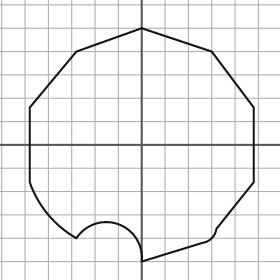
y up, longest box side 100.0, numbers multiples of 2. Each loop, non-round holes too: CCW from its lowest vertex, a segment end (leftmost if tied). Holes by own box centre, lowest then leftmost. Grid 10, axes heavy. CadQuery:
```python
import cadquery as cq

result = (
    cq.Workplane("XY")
    .moveTo(0.0, -50.0)
    .lineTo(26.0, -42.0)
    .threePointArc((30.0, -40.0), (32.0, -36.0))
    .lineTo(48.0, -16.0)
    .lineTo(48.0, 16.0)
    .lineTo(30.0, 40.0)
    .lineTo(0.0, 50.0)
    .lineTo(-28.0, 40.0)
    .lineTo(-48.0, 16.0)
    .lineTo(-48.0, -16.0)
    .threePointArc((-40.0, -30.0), (-28.0, -40.0))
    .threePointArc((-10.0, -34.0), (0.0, -50.0))
    .close()
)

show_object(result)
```